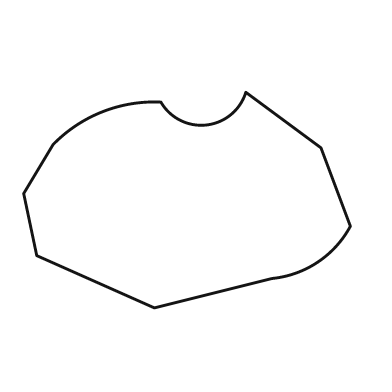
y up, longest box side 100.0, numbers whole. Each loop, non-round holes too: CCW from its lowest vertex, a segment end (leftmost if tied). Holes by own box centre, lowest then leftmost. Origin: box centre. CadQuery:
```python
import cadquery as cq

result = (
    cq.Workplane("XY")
    .moveTo(-10.0, -33.0)
    .lineTo(26.0, -24.0)
    .threePointArc((40.0, -19.0), (50.0, -8.0))
    .lineTo(41.0, 16.0)
    .lineTo(18.0, 33.0)
    .threePointArc((6.0, 23.0), (-8.0, 30.0))
    .threePointArc((-26.0, 27.0), (-41.0, 17.0))
    .lineTo(-50.0, 2.0)
    .lineTo(-46.0, -17.0)
    .close()
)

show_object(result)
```